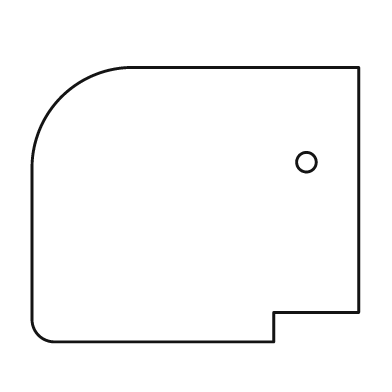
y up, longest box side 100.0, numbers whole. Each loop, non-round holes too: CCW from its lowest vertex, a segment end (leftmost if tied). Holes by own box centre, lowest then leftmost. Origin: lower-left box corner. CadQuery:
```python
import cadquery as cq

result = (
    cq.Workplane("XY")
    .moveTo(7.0, 0.0)
    .lineTo(74.0, 0.0)
    .lineTo(74.0, 9.0)
    .lineTo(100.0, 9.0)
    .lineTo(100.0, 84.0)
    .lineTo(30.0, 84.0)
    .threePointArc((9.0, 75.0), (0.0, 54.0))
    .lineTo(0.0, 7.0)
    .threePointArc((2.0, 2.0), (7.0, 0.0))
    .close()
    .moveTo(84.0, 55.0)
    .circle(3.0)
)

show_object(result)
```